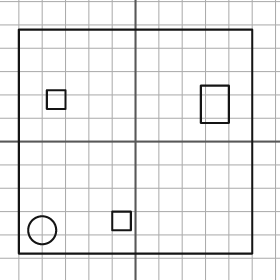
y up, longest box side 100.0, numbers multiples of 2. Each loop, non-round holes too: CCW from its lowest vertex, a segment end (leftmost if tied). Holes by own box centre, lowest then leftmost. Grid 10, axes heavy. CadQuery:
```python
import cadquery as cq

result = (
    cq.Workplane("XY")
    .moveTo(-50.0, -48.0)
    .lineTo(50.0, -48.0)
    .lineTo(50.0, 48.0)
    .lineTo(-50.0, 48.0)
    .close()
    .moveTo(-40.0, -38.0)
    .circle(6.0)
    .moveTo(-10.0, -38.0)
    .lineTo(-2.0, -38.0)
    .lineTo(-2.0, -30.0)
    .lineTo(-10.0, -30.0)
    .close()
    .moveTo(28.0, 8.0)
    .lineTo(40.0, 8.0)
    .lineTo(40.0, 24.0)
    .lineTo(28.0, 24.0)
    .close()
    .moveTo(-38.0, 14.0)
    .lineTo(-30.0, 14.0)
    .lineTo(-30.0, 22.0)
    .lineTo(-38.0, 22.0)
    .close()
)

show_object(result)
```